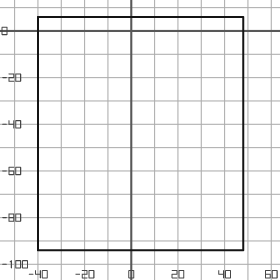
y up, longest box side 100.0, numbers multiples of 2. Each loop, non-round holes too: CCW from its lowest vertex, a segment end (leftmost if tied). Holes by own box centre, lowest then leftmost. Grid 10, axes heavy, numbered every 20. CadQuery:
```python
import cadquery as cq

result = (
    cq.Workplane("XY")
    .moveTo(-40.0, -94.0)
    .lineTo(48.0, -94.0)
    .lineTo(48.0, 6.0)
    .lineTo(-40.0, 6.0)
    .close()
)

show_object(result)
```